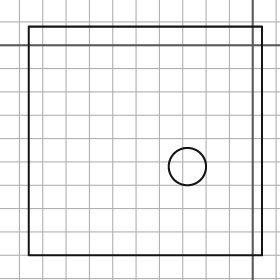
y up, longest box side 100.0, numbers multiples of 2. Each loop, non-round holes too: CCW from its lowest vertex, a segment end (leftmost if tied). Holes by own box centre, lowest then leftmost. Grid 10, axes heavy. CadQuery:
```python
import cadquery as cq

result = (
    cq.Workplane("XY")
    .moveTo(-96.0, -90.0)
    .lineTo(4.0, -90.0)
    .lineTo(4.0, 8.0)
    .lineTo(-96.0, 8.0)
    .close()
    .moveTo(-28.0, -52.0)
    .circle(8.0)
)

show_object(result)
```